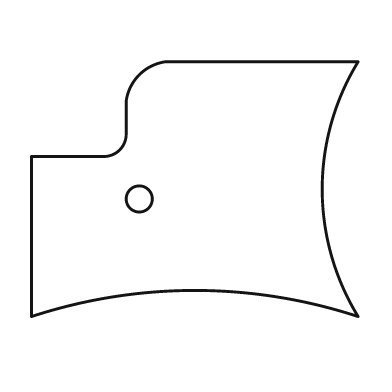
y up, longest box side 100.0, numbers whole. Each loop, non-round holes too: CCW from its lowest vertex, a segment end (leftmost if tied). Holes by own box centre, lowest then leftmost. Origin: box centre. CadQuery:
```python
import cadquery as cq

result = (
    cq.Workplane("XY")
    .moveTo(-50.0, -39.0)
    .threePointArc((0.0, -31.0), (50.0, -39.0))
    .threePointArc((39.0, 0.0), (50.0, 39.0))
    .lineTo(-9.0, 39.0)
    .threePointArc((-17.0, 35.0), (-21.0, 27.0))
    .lineTo(-21.0, 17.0)
    .threePointArc((-23.0, 12.0), (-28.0, 10.0))
    .lineTo(-50.0, 10.0)
    .close()
    .moveTo(-17.0, -3.0)
    .circle(4.0)
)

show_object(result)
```